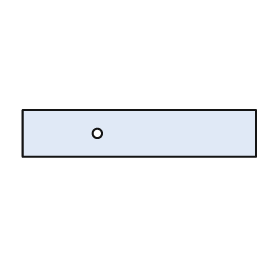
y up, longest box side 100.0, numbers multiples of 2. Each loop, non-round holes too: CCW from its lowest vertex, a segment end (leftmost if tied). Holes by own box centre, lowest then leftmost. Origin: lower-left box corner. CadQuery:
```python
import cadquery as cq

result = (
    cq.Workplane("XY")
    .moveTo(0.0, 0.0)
    .lineTo(100.0, 0.0)
    .lineTo(100.0, 20.0)
    .lineTo(0.0, 20.0)
    .close()
    .moveTo(32.0, 10.0)
    .circle(2.0)
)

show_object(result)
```